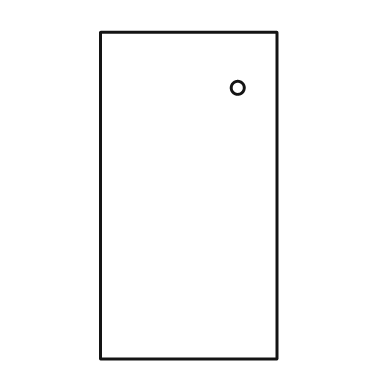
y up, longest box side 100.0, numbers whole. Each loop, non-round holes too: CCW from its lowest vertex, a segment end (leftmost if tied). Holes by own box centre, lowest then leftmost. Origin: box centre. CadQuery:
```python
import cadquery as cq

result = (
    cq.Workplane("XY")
    .moveTo(-27.0, -50.0)
    .lineTo(27.0, -50.0)
    .lineTo(27.0, 50.0)
    .lineTo(-27.0, 50.0)
    .close()
    .moveTo(15.0, 33.0)
    .circle(2.0)
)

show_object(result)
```